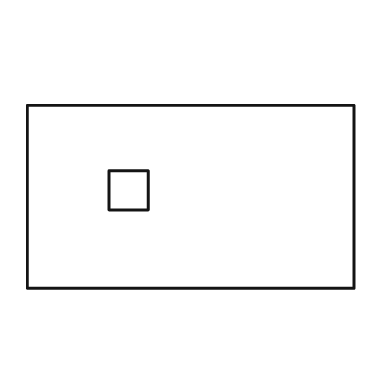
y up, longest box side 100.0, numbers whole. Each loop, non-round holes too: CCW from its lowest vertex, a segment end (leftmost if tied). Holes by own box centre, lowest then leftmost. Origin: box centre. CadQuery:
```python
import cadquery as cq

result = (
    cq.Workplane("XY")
    .moveTo(-50.0, -28.0)
    .lineTo(50.0, -28.0)
    .lineTo(50.0, 28.0)
    .lineTo(-50.0, 28.0)
    .close()
    .moveTo(-25.0, -4.0)
    .lineTo(-13.0, -4.0)
    .lineTo(-13.0, 8.0)
    .lineTo(-25.0, 8.0)
    .close()
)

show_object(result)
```